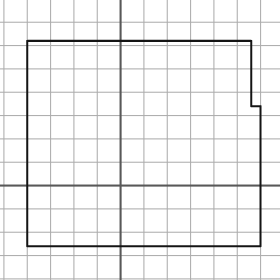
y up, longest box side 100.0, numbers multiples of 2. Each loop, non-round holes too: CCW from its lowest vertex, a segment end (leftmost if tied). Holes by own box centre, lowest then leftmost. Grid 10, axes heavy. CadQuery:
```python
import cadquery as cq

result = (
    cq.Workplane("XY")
    .moveTo(-40.0, -26.0)
    .lineTo(60.0, -26.0)
    .lineTo(60.0, 34.0)
    .lineTo(56.0, 34.0)
    .lineTo(56.0, 62.0)
    .lineTo(-40.0, 62.0)
    .close()
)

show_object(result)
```